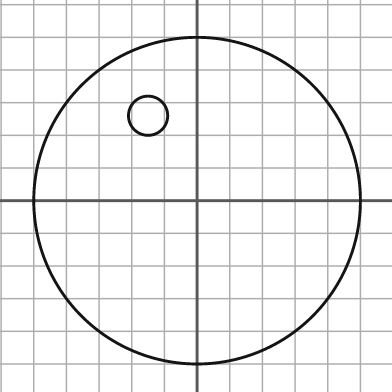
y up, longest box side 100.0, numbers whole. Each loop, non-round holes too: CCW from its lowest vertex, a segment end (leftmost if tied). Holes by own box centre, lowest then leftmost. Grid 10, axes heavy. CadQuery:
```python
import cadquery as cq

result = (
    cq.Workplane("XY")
    .moveTo(0.0, 0.0)
    .circle(50.0)
    .moveTo(-15.0, 26.0)
    .circle(6.0)
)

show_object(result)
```